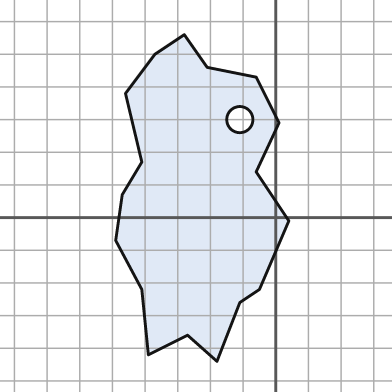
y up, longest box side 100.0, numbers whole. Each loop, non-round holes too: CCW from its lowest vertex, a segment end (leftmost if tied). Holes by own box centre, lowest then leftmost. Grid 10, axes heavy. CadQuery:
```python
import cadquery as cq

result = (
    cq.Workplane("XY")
    .moveTo(-18.0, -44.0)
    .lineTo(-11.0, -26.0)
    .lineTo(-5.0, -22.0)
    .lineTo(4.0, -1.0)
    .lineTo(-6.0, 14.0)
    .lineTo(1.0, 29.0)
    .lineTo(-6.0, 43.0)
    .lineTo(-21.0, 46.0)
    .lineTo(-28.0, 56.0)
    .lineTo(-37.0, 50.0)
    .lineTo(-46.0, 38.0)
    .lineTo(-41.0, 17.0)
    .lineTo(-47.0, 7.0)
    .lineTo(-49.0, -7.0)
    .lineTo(-41.0, -22.0)
    .lineTo(-39.0, -42.0)
    .lineTo(-27.0, -36.0)
    .close()
    .moveTo(-11.0, 30.0)
    .circle(4.0)
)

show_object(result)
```